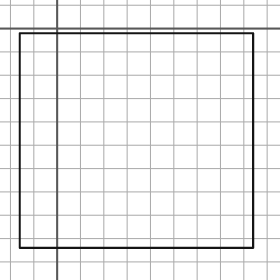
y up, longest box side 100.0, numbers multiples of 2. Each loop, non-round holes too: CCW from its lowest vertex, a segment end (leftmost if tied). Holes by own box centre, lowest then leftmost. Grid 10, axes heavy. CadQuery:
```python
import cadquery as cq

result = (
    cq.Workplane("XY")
    .moveTo(-16.0, -94.0)
    .lineTo(84.0, -94.0)
    .lineTo(84.0, -2.0)
    .lineTo(-16.0, -2.0)
    .close()
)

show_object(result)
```